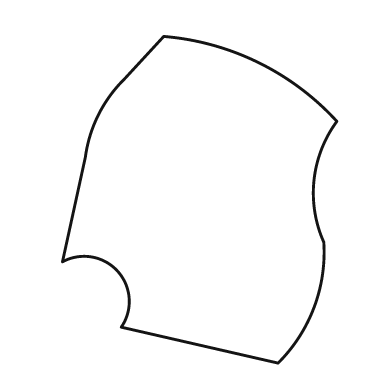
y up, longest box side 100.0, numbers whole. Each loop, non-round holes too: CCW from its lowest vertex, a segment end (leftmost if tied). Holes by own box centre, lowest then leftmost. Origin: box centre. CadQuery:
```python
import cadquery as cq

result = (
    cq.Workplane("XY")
    .moveTo(24.0, -50.0)
    .threePointArc((35.0, -33.0), (38.0, -13.0))
    .threePointArc((35.0, 6.0), (42.0, 24.0))
    .threePointArc((18.0, 42.0), (-11.0, 50.0))
    .lineTo(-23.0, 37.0)
    .threePointArc((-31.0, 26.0), (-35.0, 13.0))
    .lineTo(-42.0, -19.0)
    .threePointArc((-25.0, -22.0), (-24.0, -39.0))
    .close()
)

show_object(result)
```